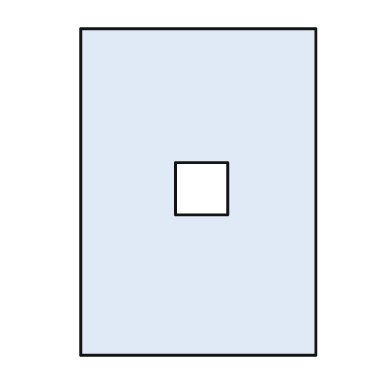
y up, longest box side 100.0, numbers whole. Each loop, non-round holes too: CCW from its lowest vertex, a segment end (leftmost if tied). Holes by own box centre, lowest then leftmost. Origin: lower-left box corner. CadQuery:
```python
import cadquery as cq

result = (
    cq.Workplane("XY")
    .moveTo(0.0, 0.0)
    .lineTo(72.0, 0.0)
    .lineTo(72.0, 100.0)
    .lineTo(0.0, 100.0)
    .close()
    .moveTo(29.0, 43.0)
    .lineTo(45.0, 43.0)
    .lineTo(45.0, 59.0)
    .lineTo(29.0, 59.0)
    .close()
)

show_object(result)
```